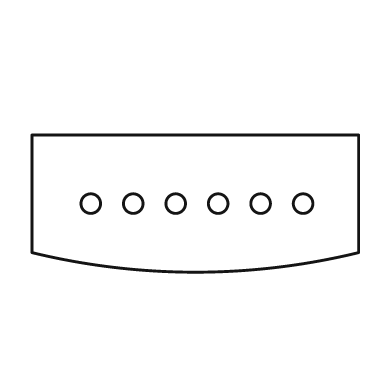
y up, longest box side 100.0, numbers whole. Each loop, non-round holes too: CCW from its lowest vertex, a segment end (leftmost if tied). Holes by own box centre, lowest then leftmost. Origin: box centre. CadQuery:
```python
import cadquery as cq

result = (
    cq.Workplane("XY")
    .moveTo(-50.0, -15.0)
    .threePointArc((0.0, -21.0), (50.0, -15.0))
    .lineTo(50.0, 21.0)
    .lineTo(-50.0, 21.0)
    .close()
    .moveTo(-32.0, 0.0)
    .circle(3.0)
    .moveTo(-19.0, 0.0)
    .circle(3.0)
    .moveTo(-6.0, 0.0)
    .circle(3.0)
    .moveTo(7.0, 0.0)
    .circle(3.0)
    .moveTo(20.0, 0.0)
    .circle(3.0)
    .moveTo(33.0, 0.0)
    .circle(3.0)
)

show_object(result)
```